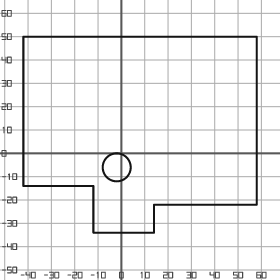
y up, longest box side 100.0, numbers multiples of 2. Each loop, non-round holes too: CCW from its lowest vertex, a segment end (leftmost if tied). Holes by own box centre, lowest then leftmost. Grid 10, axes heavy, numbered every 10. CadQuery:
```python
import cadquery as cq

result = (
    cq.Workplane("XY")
    .moveTo(-12.0, -34.0)
    .lineTo(14.0, -34.0)
    .lineTo(14.0, -22.0)
    .lineTo(58.0, -22.0)
    .lineTo(58.0, 50.0)
    .lineTo(-42.0, 50.0)
    .lineTo(-42.0, -14.0)
    .lineTo(-12.0, -14.0)
    .close()
    .moveTo(-2.0, -6.0)
    .circle(6.0)
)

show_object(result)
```